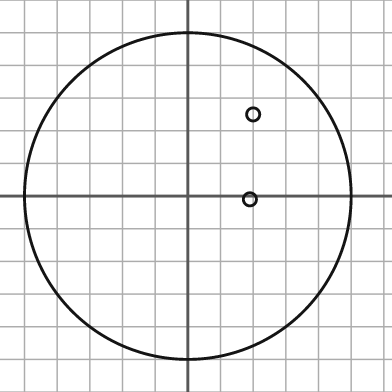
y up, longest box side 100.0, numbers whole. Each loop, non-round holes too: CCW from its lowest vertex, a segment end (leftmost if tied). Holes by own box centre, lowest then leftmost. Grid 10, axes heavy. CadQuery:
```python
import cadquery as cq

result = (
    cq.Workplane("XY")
    .moveTo(0.0, 0.0)
    .circle(50.0)
    .moveTo(19.0, -1.0)
    .circle(2.0)
    .moveTo(20.0, 25.0)
    .circle(2.0)
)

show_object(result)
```